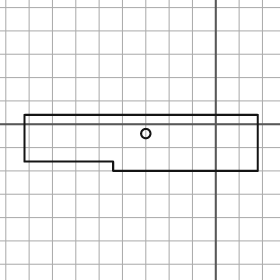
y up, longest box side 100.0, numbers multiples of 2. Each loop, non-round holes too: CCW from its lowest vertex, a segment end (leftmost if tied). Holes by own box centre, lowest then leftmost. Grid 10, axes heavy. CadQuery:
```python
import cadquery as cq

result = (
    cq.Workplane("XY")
    .moveTo(-44.0, -20.0)
    .lineTo(18.0, -20.0)
    .lineTo(18.0, 4.0)
    .lineTo(-82.0, 4.0)
    .lineTo(-82.0, -16.0)
    .lineTo(-44.0, -16.0)
    .close()
    .moveTo(-30.0, -4.0)
    .circle(2.0)
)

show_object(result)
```